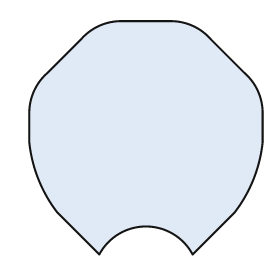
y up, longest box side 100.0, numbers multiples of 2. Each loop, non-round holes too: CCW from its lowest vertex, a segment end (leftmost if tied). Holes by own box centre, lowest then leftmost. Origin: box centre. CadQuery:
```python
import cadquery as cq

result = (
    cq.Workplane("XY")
    .moveTo(-20.0, -50.0)
    .threePointArc((0.0, -38.0), (20.0, -50.0))
    .lineTo(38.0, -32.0)
    .threePointArc((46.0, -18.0), (50.0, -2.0))
    .lineTo(50.0, 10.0)
    .threePointArc((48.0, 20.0), (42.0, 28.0))
    .lineTo(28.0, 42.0)
    .threePointArc((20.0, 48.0), (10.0, 50.0))
    .lineTo(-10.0, 50.0)
    .threePointArc((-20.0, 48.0), (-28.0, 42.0))
    .lineTo(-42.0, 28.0)
    .threePointArc((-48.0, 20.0), (-50.0, 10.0))
    .lineTo(-50.0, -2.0)
    .threePointArc((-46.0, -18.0), (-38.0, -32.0))
    .close()
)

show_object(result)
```